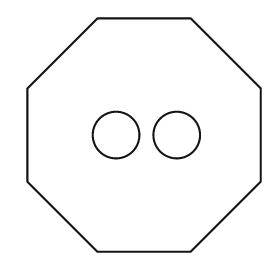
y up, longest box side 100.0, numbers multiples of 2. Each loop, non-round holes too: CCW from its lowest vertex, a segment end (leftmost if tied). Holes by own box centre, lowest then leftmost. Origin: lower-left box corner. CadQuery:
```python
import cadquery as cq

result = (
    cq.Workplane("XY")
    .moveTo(30.0, 0.0)
    .lineTo(70.0, 0.0)
    .lineTo(100.0, 30.0)
    .lineTo(100.0, 70.0)
    .lineTo(70.0, 100.0)
    .lineTo(30.0, 100.0)
    .lineTo(0.0, 70.0)
    .lineTo(0.0, 30.0)
    .close()
    .moveTo(38.0, 50.0)
    .circle(10.0)
    .moveTo(64.0, 50.0)
    .circle(10.0)
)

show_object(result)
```